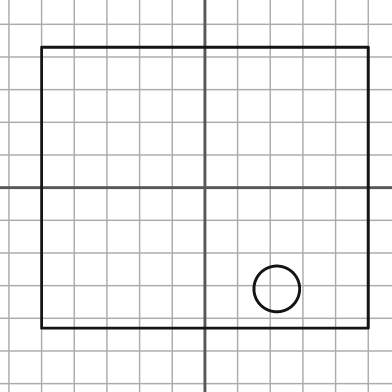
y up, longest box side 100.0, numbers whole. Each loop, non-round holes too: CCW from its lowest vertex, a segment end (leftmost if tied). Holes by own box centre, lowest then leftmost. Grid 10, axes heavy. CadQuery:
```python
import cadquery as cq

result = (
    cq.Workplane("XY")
    .moveTo(-50.0, -43.0)
    .lineTo(50.0, -43.0)
    .lineTo(50.0, 43.0)
    .lineTo(-50.0, 43.0)
    .close()
    .moveTo(22.0, -31.0)
    .circle(7.0)
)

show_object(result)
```